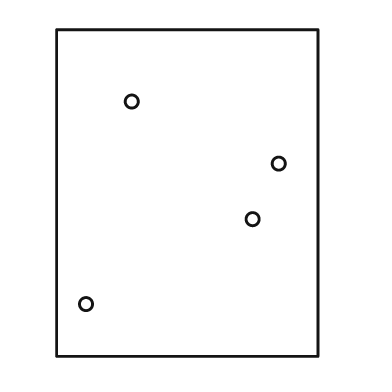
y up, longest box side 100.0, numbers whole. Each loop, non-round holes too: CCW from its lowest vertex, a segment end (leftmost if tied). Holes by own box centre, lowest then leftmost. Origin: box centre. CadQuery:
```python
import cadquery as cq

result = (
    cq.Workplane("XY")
    .moveTo(-40.0, -50.0)
    .lineTo(40.0, -50.0)
    .lineTo(40.0, 50.0)
    .lineTo(-40.0, 50.0)
    .close()
    .moveTo(-31.0, -34.0)
    .circle(2.0)
    .moveTo(20.0, -8.0)
    .circle(2.0)
    .moveTo(28.0, 9.0)
    .circle(2.0)
    .moveTo(-17.0, 28.0)
    .circle(2.0)
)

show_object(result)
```